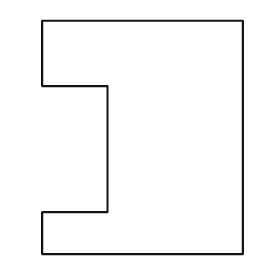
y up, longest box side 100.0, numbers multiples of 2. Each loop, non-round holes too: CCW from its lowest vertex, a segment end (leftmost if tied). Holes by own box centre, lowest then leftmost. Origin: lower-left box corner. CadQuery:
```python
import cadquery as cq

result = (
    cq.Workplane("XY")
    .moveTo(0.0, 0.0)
    .lineTo(86.0, 0.0)
    .lineTo(86.0, 100.0)
    .lineTo(0.0, 100.0)
    .lineTo(0.0, 72.0)
    .lineTo(28.0, 72.0)
    .lineTo(28.0, 18.0)
    .lineTo(0.0, 18.0)
    .close()
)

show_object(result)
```